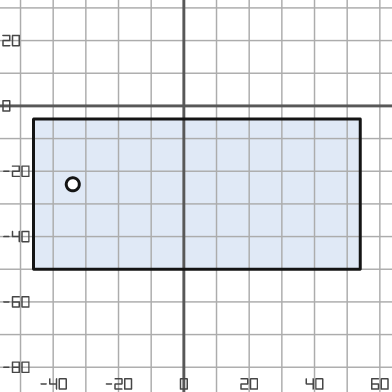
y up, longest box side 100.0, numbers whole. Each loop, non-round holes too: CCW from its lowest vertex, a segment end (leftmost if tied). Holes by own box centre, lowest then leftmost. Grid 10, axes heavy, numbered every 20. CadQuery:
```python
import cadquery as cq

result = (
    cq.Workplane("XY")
    .moveTo(-46.0, -50.0)
    .lineTo(54.0, -50.0)
    .lineTo(54.0, -4.0)
    .lineTo(-46.0, -4.0)
    .close()
    .moveTo(-34.0, -24.0)
    .circle(2.0)
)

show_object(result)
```